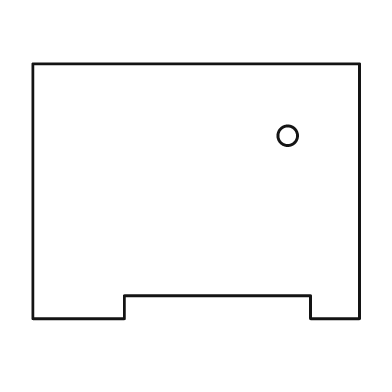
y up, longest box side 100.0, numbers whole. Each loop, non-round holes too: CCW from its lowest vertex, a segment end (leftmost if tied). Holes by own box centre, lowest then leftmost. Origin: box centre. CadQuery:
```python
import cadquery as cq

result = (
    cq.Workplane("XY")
    .moveTo(-50.0, -39.0)
    .lineTo(-22.0, -39.0)
    .lineTo(-22.0, -32.0)
    .lineTo(35.0, -32.0)
    .lineTo(35.0, -39.0)
    .lineTo(50.0, -39.0)
    .lineTo(50.0, 39.0)
    .lineTo(-50.0, 39.0)
    .close()
    .moveTo(28.0, 17.0)
    .circle(3.0)
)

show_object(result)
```